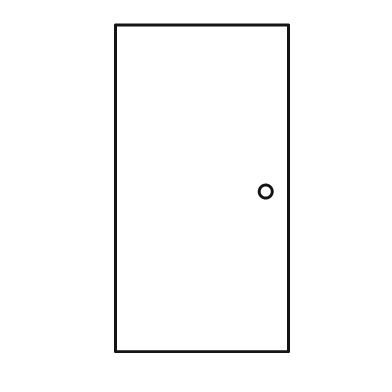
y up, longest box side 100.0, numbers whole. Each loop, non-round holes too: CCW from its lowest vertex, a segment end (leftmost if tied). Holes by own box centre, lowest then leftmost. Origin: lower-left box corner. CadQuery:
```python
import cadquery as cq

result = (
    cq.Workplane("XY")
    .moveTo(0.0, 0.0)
    .lineTo(53.0, 0.0)
    .lineTo(53.0, 100.0)
    .lineTo(0.0, 100.0)
    .close()
    .moveTo(46.0, 49.0)
    .circle(2.0)
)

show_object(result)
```